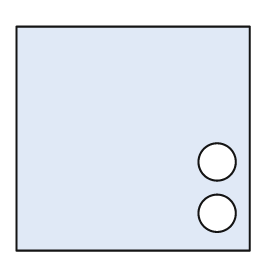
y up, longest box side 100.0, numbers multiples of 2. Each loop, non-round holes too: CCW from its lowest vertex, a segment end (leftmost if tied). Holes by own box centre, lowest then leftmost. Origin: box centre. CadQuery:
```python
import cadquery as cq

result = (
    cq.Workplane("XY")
    .moveTo(-50.0, -48.0)
    .lineTo(50.0, -48.0)
    .lineTo(50.0, 48.0)
    .lineTo(-50.0, 48.0)
    .close()
    .moveTo(36.0, -32.0)
    .circle(8.0)
    .moveTo(36.0, -10.0)
    .circle(8.0)
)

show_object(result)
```